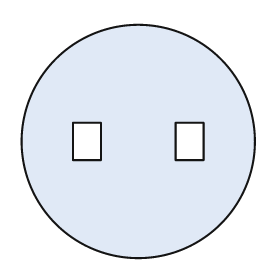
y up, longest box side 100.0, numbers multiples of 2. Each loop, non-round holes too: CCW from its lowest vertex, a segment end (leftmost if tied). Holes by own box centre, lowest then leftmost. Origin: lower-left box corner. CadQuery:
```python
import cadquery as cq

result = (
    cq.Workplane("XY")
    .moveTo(50.0, 50.0)
    .circle(50.0)
    .moveTo(22.0, 42.0)
    .lineTo(34.0, 42.0)
    .lineTo(34.0, 58.0)
    .lineTo(22.0, 58.0)
    .close()
    .moveTo(66.0, 42.0)
    .lineTo(78.0, 42.0)
    .lineTo(78.0, 58.0)
    .lineTo(66.0, 58.0)
    .close()
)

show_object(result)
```